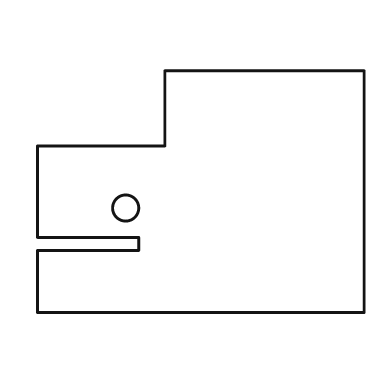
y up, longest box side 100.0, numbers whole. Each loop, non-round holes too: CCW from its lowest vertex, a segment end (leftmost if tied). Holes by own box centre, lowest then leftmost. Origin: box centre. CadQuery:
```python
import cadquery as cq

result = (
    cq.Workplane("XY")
    .moveTo(-50.0, -37.0)
    .lineTo(50.0, -37.0)
    .lineTo(50.0, 37.0)
    .lineTo(-11.0, 37.0)
    .lineTo(-11.0, 14.0)
    .lineTo(-50.0, 14.0)
    .lineTo(-50.0, -14.0)
    .lineTo(-19.0, -14.0)
    .lineTo(-19.0, -18.0)
    .lineTo(-50.0, -18.0)
    .close()
    .moveTo(-23.0, -5.0)
    .circle(4.0)
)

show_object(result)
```